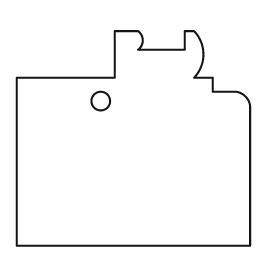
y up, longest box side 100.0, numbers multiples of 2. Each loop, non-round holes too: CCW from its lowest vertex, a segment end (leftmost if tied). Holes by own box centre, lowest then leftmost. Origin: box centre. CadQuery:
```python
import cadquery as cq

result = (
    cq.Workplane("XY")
    .moveTo(-50.0, -46.0)
    .lineTo(50.0, -46.0)
    .lineTo(50.0, 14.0)
    .threePointArc((48.0, 18.0), (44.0, 20.0))
    .lineTo(34.0, 20.0)
    .lineTo(34.0, 26.0)
    .lineTo(26.0, 26.0)
    .threePointArc((30.0, 36.0), (26.0, 46.0))
    .lineTo(22.0, 46.0)
    .lineTo(22.0, 38.0)
    .lineTo(2.0, 38.0)
    .threePointArc((4.0, 42.0), (2.0, 46.0))
    .lineTo(-8.0, 46.0)
    .lineTo(-8.0, 26.0)
    .lineTo(-50.0, 26.0)
    .close()
    .moveTo(-14.0, 16.0)
    .circle(4.0)
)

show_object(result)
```